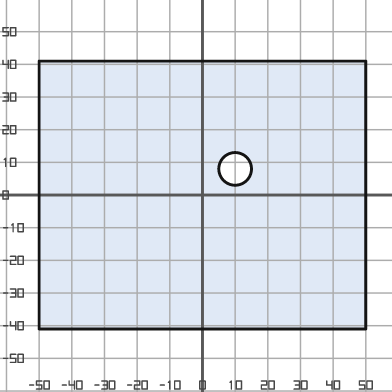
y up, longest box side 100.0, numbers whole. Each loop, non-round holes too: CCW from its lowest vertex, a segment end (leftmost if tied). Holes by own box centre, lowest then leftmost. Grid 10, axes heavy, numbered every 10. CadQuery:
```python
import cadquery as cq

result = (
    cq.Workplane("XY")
    .moveTo(-50.0, -41.0)
    .lineTo(50.0, -41.0)
    .lineTo(50.0, 41.0)
    .lineTo(-50.0, 41.0)
    .close()
    .moveTo(10.0, 8.0)
    .circle(5.0)
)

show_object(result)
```